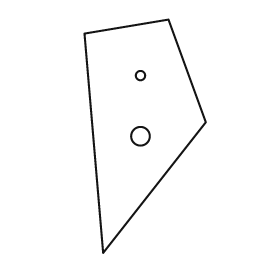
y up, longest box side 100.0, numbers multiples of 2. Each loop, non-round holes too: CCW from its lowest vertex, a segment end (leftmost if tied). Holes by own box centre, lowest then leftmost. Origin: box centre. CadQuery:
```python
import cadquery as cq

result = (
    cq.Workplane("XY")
    .moveTo(-18.0, -50.0)
    .lineTo(26.0, 6.0)
    .lineTo(10.0, 50.0)
    .lineTo(-26.0, 44.0)
    .close()
    .moveTo(-2.0, 0.0)
    .circle(4.0)
    .moveTo(-2.0, 26.0)
    .circle(2.0)
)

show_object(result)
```